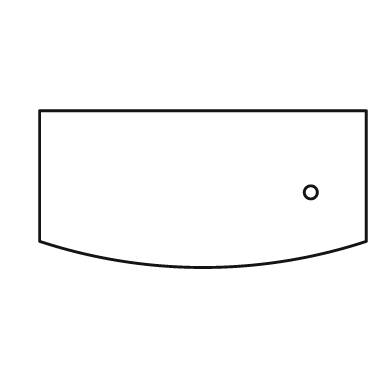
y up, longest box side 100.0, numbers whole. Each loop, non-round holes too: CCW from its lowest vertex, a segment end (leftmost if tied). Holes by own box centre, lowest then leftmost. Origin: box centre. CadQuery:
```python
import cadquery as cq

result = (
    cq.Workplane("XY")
    .moveTo(-50.0, -16.0)
    .threePointArc((0.0, -24.0), (50.0, -16.0))
    .lineTo(50.0, 24.0)
    .lineTo(-50.0, 24.0)
    .close()
    .moveTo(33.0, -1.0)
    .circle(2.0)
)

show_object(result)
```